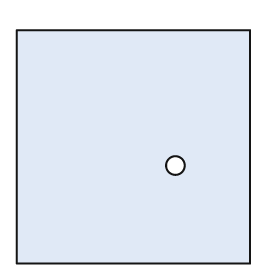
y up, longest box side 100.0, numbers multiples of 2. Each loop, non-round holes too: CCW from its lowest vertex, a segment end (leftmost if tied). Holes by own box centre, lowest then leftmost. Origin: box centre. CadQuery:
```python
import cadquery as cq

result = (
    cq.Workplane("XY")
    .moveTo(-50.0, -50.0)
    .lineTo(50.0, -50.0)
    .lineTo(50.0, 50.0)
    .lineTo(-50.0, 50.0)
    .close()
    .moveTo(18.0, -8.0)
    .circle(4.0)
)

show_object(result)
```